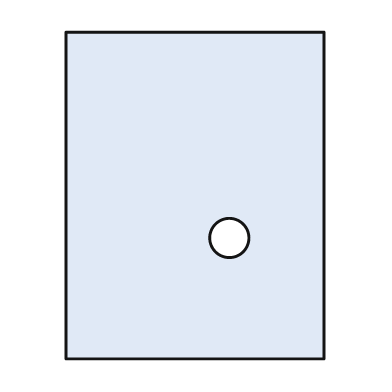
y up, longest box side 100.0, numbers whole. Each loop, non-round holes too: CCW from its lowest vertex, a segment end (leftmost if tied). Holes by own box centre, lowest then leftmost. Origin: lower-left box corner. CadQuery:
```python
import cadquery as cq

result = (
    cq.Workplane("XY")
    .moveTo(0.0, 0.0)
    .lineTo(79.0, 0.0)
    .lineTo(79.0, 100.0)
    .lineTo(0.0, 100.0)
    .close()
    .moveTo(50.0, 37.0)
    .circle(6.0)
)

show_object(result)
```